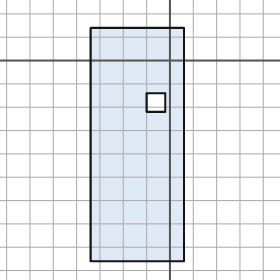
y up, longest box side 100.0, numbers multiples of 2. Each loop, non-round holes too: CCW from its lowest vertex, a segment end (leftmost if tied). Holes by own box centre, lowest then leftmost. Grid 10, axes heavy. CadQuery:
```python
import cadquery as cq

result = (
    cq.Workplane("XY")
    .moveTo(-34.0, -86.0)
    .lineTo(6.0, -86.0)
    .lineTo(6.0, 14.0)
    .lineTo(-34.0, 14.0)
    .close()
    .moveTo(-10.0, -22.0)
    .lineTo(-2.0, -22.0)
    .lineTo(-2.0, -14.0)
    .lineTo(-10.0, -14.0)
    .close()
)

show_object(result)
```